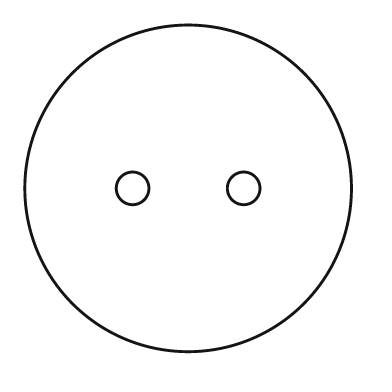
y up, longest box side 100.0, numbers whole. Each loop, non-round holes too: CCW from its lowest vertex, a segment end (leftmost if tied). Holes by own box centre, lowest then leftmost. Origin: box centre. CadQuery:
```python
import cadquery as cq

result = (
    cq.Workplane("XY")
    .moveTo(0.0, 0.0)
    .circle(50.0)
    .moveTo(-17.0, 0.0)
    .circle(5.0)
    .moveTo(17.0, 0.0)
    .circle(5.0)
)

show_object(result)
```